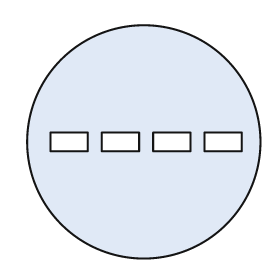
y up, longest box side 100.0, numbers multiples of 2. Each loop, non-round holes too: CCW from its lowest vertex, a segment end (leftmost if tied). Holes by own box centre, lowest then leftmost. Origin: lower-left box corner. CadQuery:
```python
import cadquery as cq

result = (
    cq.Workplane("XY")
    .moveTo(50.0, 50.0)
    .circle(50.0)
    .moveTo(10.0, 46.0)
    .lineTo(26.0, 46.0)
    .lineTo(26.0, 54.0)
    .lineTo(10.0, 54.0)
    .close()
    .moveTo(32.0, 46.0)
    .lineTo(48.0, 46.0)
    .lineTo(48.0, 54.0)
    .lineTo(32.0, 54.0)
    .close()
    .moveTo(54.0, 46.0)
    .lineTo(70.0, 46.0)
    .lineTo(70.0, 54.0)
    .lineTo(54.0, 54.0)
    .close()
    .moveTo(76.0, 46.0)
    .lineTo(92.0, 46.0)
    .lineTo(92.0, 54.0)
    .lineTo(76.0, 54.0)
    .close()
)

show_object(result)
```